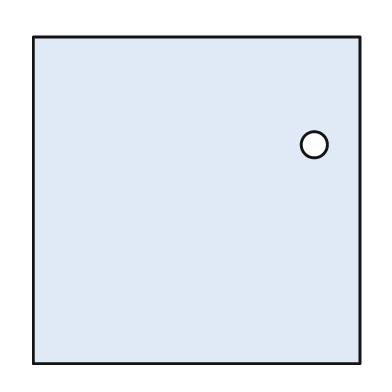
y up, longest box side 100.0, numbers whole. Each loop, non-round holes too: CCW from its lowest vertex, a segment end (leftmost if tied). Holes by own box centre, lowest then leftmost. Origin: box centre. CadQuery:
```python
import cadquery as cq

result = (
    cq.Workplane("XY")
    .moveTo(-50.0, -50.0)
    .lineTo(50.0, -50.0)
    .lineTo(50.0, 50.0)
    .lineTo(-50.0, 50.0)
    .close()
    .moveTo(36.0, 17.0)
    .circle(4.0)
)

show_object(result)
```